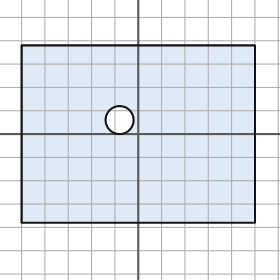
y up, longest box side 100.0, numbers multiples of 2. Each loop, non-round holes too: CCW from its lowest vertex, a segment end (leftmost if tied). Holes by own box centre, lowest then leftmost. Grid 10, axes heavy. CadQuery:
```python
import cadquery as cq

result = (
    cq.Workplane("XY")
    .moveTo(-50.0, -38.0)
    .lineTo(50.0, -38.0)
    .lineTo(50.0, 38.0)
    .lineTo(-50.0, 38.0)
    .close()
    .moveTo(-8.0, 6.0)
    .circle(6.0)
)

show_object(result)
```